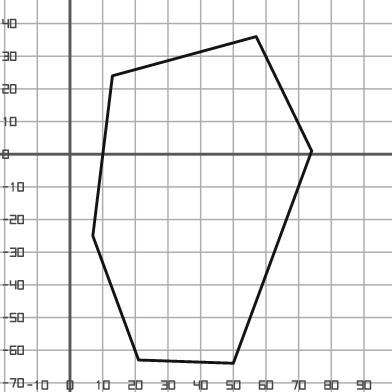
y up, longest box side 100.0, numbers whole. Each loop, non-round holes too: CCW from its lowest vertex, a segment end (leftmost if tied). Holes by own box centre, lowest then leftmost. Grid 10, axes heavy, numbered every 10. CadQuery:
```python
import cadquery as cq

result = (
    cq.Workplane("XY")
    .moveTo(50.0, -64.0)
    .lineTo(74.0, 1.0)
    .lineTo(57.0, 36.0)
    .lineTo(13.0, 24.0)
    .lineTo(7.0, -25.0)
    .lineTo(21.0, -63.0)
    .close()
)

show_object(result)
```